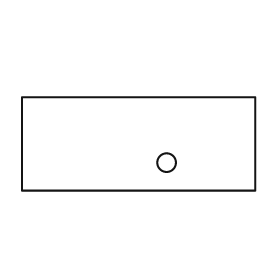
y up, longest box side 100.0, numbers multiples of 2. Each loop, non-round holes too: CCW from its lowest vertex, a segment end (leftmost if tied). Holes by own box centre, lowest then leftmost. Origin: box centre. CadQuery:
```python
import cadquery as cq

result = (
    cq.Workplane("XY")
    .moveTo(-50.0, -20.0)
    .lineTo(50.0, -20.0)
    .lineTo(50.0, 20.0)
    .lineTo(-50.0, 20.0)
    .close()
    .moveTo(12.0, -8.0)
    .circle(4.0)
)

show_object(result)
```